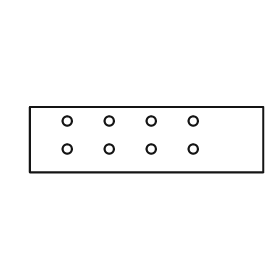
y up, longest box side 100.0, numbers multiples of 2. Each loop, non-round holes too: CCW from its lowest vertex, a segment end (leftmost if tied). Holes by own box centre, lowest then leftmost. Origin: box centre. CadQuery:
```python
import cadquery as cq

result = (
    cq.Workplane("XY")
    .moveTo(-50.0, -14.0)
    .lineTo(50.0, -14.0)
    .lineTo(50.0, 14.0)
    .lineTo(-50.0, 14.0)
    .close()
    .moveTo(-34.0, -4.0)
    .circle(2.0)
    .moveTo(-16.0, -4.0)
    .circle(2.0)
    .moveTo(2.0, -4.0)
    .circle(2.0)
    .moveTo(20.0, -4.0)
    .circle(2.0)
    .moveTo(-34.0, 8.0)
    .circle(2.0)
    .moveTo(-16.0, 8.0)
    .circle(2.0)
    .moveTo(2.0, 8.0)
    .circle(2.0)
    .moveTo(20.0, 8.0)
    .circle(2.0)
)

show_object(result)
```